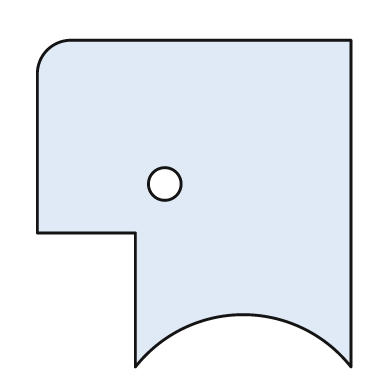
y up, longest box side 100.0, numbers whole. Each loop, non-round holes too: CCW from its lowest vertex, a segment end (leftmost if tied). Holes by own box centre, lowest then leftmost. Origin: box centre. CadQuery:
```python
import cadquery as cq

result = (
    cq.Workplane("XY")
    .moveTo(-18.0, -50.0)
    .threePointArc((15.0, -34.0), (48.0, -50.0))
    .lineTo(48.0, 50.0)
    .lineTo(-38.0, 50.0)
    .threePointArc((-45.0, 47.0), (-48.0, 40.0))
    .lineTo(-48.0, -9.0)
    .lineTo(-18.0, -9.0)
    .close()
    .moveTo(-9.0, 6.0)
    .circle(5.0)
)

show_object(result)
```